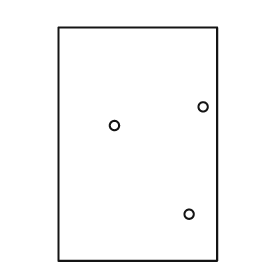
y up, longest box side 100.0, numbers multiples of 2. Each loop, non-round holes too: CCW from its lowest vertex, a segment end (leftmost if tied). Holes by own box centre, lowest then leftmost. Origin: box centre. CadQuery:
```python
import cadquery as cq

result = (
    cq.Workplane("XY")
    .moveTo(-34.0, -50.0)
    .lineTo(34.0, -50.0)
    .lineTo(34.0, 50.0)
    .lineTo(-34.0, 50.0)
    .close()
    .moveTo(22.0, -30.0)
    .circle(2.0)
    .moveTo(-10.0, 8.0)
    .circle(2.0)
    .moveTo(28.0, 16.0)
    .circle(2.0)
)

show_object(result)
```